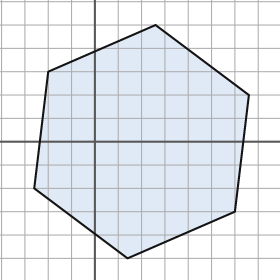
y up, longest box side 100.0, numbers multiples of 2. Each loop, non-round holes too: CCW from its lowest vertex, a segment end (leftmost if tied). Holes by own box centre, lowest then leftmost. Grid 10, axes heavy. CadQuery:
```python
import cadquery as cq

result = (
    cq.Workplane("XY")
    .moveTo(14.0, -50.0)
    .lineTo(60.0, -30.0)
    .lineTo(66.0, 20.0)
    .lineTo(26.0, 50.0)
    .lineTo(-20.0, 30.0)
    .lineTo(-26.0, -20.0)
    .close()
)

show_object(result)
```